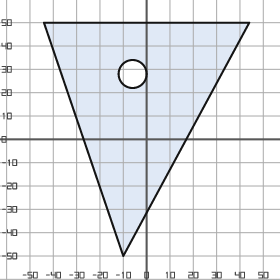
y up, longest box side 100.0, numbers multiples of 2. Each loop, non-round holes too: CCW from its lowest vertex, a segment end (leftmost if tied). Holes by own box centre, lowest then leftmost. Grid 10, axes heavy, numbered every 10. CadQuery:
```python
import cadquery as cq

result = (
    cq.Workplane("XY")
    .moveTo(-10.0, -50.0)
    .lineTo(44.0, 50.0)
    .lineTo(-44.0, 50.0)
    .close()
    .moveTo(-6.0, 28.0)
    .circle(6.0)
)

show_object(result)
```